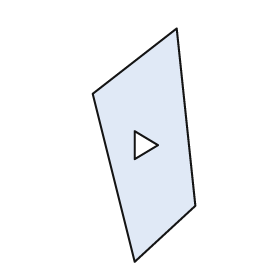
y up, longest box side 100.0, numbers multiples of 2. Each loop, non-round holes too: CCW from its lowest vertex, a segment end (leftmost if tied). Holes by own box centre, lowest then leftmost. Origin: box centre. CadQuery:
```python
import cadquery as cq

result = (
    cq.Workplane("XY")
    .moveTo(-4.0, -50.0)
    .lineTo(22.0, -26.0)
    .lineTo(14.0, 50.0)
    .lineTo(-22.0, 22.0)
    .close()
    .moveTo(-4.0, -6.0)
    .lineTo(6.0, 0.0)
    .lineTo(-4.0, 6.0)
    .close()
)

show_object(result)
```